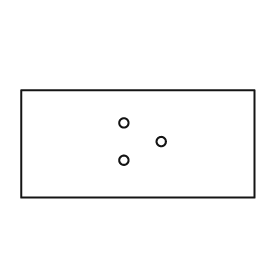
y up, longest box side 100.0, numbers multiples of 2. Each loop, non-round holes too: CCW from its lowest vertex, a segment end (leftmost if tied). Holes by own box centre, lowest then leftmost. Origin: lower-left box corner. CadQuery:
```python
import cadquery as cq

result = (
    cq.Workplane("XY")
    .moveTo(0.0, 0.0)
    .lineTo(100.0, 0.0)
    .lineTo(100.0, 46.0)
    .lineTo(0.0, 46.0)
    .close()
    .moveTo(44.0, 16.0)
    .circle(2.0)
    .moveTo(60.0, 24.0)
    .circle(2.0)
    .moveTo(44.0, 32.0)
    .circle(2.0)
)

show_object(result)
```